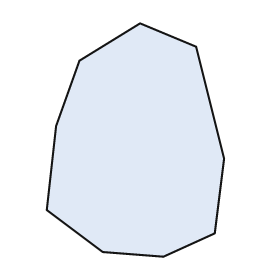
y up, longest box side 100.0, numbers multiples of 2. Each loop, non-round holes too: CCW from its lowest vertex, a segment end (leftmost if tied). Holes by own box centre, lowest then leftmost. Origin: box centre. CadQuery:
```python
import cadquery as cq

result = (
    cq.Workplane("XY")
    .moveTo(12.0, -50.0)
    .lineTo(34.0, -40.0)
    .lineTo(38.0, -8.0)
    .lineTo(26.0, 40.0)
    .lineTo(2.0, 50.0)
    .lineTo(-24.0, 34.0)
    .lineTo(-34.0, 6.0)
    .lineTo(-38.0, -30.0)
    .lineTo(-14.0, -48.0)
    .close()
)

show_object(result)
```